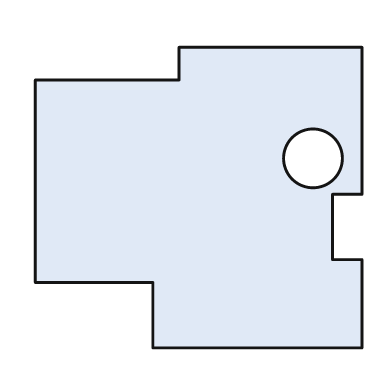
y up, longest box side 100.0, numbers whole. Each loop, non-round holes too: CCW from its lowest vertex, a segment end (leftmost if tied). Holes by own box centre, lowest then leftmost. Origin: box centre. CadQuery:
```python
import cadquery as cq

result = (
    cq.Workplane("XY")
    .moveTo(-14.0, -46.0)
    .lineTo(50.0, -46.0)
    .lineTo(50.0, -19.0)
    .lineTo(41.0, -19.0)
    .lineTo(41.0, 1.0)
    .lineTo(50.0, 1.0)
    .lineTo(50.0, 46.0)
    .lineTo(-6.0, 46.0)
    .lineTo(-6.0, 36.0)
    .lineTo(-50.0, 36.0)
    .lineTo(-50.0, -26.0)
    .lineTo(-14.0, -26.0)
    .close()
    .moveTo(35.0, 12.0)
    .circle(9.0)
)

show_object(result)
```